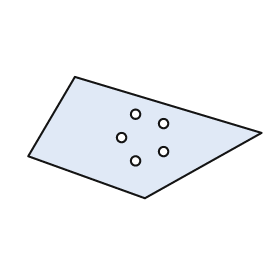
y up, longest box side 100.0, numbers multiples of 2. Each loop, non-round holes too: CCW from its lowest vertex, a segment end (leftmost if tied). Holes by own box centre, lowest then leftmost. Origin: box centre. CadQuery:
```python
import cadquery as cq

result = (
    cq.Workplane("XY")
    .moveTo(0.0, -26.0)
    .lineTo(50.0, 2.0)
    .lineTo(-30.0, 26.0)
    .lineTo(-50.0, -8.0)
    .close()
    .moveTo(-4.0, -10.0)
    .circle(2.0)
    .moveTo(8.0, -6.0)
    .circle(2.0)
    .moveTo(-10.0, 0.0)
    .circle(2.0)
    .moveTo(8.0, 6.0)
    .circle(2.0)
    .moveTo(-4.0, 10.0)
    .circle(2.0)
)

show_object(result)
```